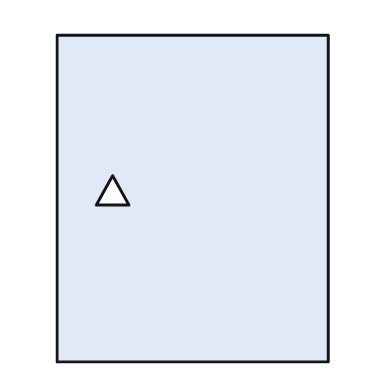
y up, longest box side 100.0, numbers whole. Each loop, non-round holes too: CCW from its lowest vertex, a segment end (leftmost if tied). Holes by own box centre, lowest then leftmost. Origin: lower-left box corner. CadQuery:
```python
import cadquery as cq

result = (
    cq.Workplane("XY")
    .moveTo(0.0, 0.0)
    .lineTo(83.0, 0.0)
    .lineTo(83.0, 100.0)
    .lineTo(0.0, 100.0)
    .close()
    .moveTo(12.0, 48.0)
    .lineTo(22.0, 48.0)
    .lineTo(17.0, 57.0)
    .close()
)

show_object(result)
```